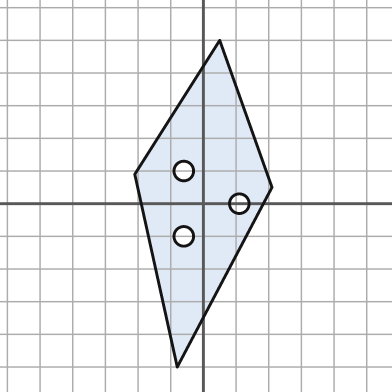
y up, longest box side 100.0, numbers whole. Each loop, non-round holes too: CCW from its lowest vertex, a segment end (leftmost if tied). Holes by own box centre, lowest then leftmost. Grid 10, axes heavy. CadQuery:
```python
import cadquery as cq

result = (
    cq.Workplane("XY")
    .moveTo(-8.0, -50.0)
    .lineTo(21.0, 5.0)
    .lineTo(5.0, 50.0)
    .lineTo(-21.0, 9.0)
    .close()
    .moveTo(-6.0, -10.0)
    .circle(3.0)
    .moveTo(11.0, 0.0)
    .circle(3.0)
    .moveTo(-6.0, 10.0)
    .circle(3.0)
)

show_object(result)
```